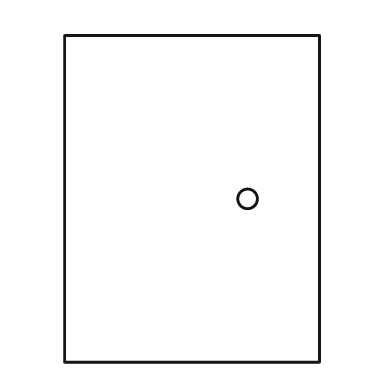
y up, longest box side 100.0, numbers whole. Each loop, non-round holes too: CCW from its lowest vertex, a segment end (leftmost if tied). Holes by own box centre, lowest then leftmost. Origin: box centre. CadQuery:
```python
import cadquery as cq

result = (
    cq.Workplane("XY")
    .moveTo(-39.0, -50.0)
    .lineTo(39.0, -50.0)
    .lineTo(39.0, 50.0)
    .lineTo(-39.0, 50.0)
    .close()
    .moveTo(17.0, 0.0)
    .circle(3.0)
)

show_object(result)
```